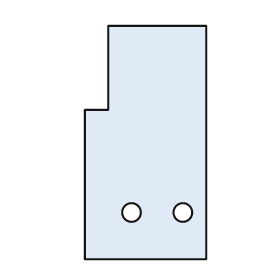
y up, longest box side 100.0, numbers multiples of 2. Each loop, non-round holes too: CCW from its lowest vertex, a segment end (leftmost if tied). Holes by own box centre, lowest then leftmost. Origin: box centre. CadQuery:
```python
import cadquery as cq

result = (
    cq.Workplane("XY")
    .moveTo(-26.0, -50.0)
    .lineTo(26.0, -50.0)
    .lineTo(26.0, 50.0)
    .lineTo(-16.0, 50.0)
    .lineTo(-16.0, 14.0)
    .lineTo(-26.0, 14.0)
    .close()
    .moveTo(-6.0, -30.0)
    .circle(4.0)
    .moveTo(16.0, -30.0)
    .circle(4.0)
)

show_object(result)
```